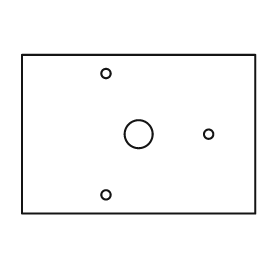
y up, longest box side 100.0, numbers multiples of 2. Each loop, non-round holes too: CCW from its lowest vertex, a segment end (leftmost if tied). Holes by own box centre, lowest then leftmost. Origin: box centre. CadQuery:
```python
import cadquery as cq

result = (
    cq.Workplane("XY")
    .moveTo(-50.0, -34.0)
    .lineTo(50.0, -34.0)
    .lineTo(50.0, 34.0)
    .lineTo(-50.0, 34.0)
    .close()
    .moveTo(-14.0, -26.0)
    .circle(2.0)
    .moveTo(0.0, 0.0)
    .circle(6.0)
    .moveTo(30.0, 0.0)
    .circle(2.0)
    .moveTo(-14.0, 26.0)
    .circle(2.0)
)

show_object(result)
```